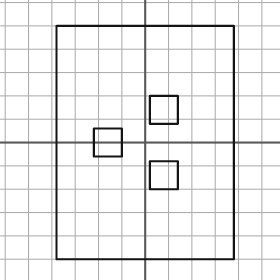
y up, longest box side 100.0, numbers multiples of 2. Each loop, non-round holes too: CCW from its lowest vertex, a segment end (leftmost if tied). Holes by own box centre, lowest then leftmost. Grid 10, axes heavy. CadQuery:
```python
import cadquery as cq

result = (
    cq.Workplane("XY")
    .moveTo(-38.0, -50.0)
    .lineTo(38.0, -50.0)
    .lineTo(38.0, 50.0)
    .lineTo(-38.0, 50.0)
    .close()
    .moveTo(2.0, -20.0)
    .lineTo(14.0, -20.0)
    .lineTo(14.0, -8.0)
    .lineTo(2.0, -8.0)
    .close()
    .moveTo(-22.0, -6.0)
    .lineTo(-10.0, -6.0)
    .lineTo(-10.0, 6.0)
    .lineTo(-22.0, 6.0)
    .close()
    .moveTo(2.0, 8.0)
    .lineTo(14.0, 8.0)
    .lineTo(14.0, 20.0)
    .lineTo(2.0, 20.0)
    .close()
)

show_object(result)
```